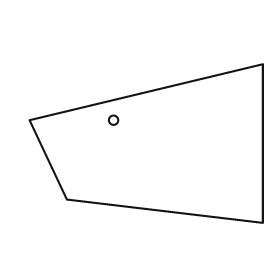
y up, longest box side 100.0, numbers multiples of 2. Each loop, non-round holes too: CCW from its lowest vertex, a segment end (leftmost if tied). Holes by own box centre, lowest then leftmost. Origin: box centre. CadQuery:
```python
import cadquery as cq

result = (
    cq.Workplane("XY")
    .moveTo(50.0, -34.0)
    .lineTo(50.0, 34.0)
    .lineTo(-50.0, 10.0)
    .lineTo(-34.0, -24.0)
    .close()
    .moveTo(-14.0, 10.0)
    .circle(2.0)
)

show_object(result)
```